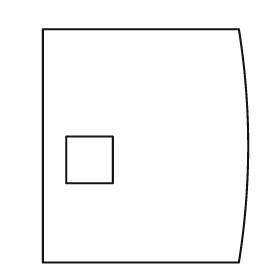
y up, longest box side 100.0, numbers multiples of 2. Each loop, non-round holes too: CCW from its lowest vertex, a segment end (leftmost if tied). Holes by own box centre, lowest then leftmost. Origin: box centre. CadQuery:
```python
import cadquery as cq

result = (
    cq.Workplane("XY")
    .moveTo(-44.0, -50.0)
    .lineTo(40.0, -50.0)
    .threePointArc((44.0, 0.0), (40.0, 50.0))
    .lineTo(-44.0, 50.0)
    .close()
    .moveTo(-34.0, -16.0)
    .lineTo(-14.0, -16.0)
    .lineTo(-14.0, 4.0)
    .lineTo(-34.0, 4.0)
    .close()
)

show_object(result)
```